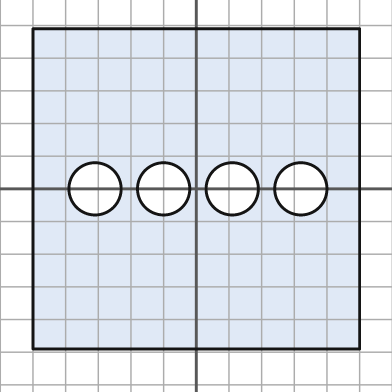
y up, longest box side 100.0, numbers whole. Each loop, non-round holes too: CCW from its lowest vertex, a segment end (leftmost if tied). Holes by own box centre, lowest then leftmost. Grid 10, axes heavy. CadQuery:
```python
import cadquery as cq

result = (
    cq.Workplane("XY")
    .moveTo(-50.0, -49.0)
    .lineTo(50.0, -49.0)
    .lineTo(50.0, 49.0)
    .lineTo(-50.0, 49.0)
    .close()
    .moveTo(-31.0, 0.0)
    .circle(8.0)
    .moveTo(-10.0, 0.0)
    .circle(8.0)
    .moveTo(11.0, 0.0)
    .circle(8.0)
    .moveTo(32.0, 0.0)
    .circle(8.0)
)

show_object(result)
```